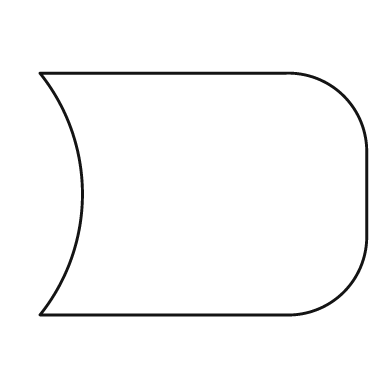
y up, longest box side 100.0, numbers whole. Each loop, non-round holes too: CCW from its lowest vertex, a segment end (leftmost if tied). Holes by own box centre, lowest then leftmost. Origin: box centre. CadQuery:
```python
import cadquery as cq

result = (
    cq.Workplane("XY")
    .moveTo(-50.0, -37.0)
    .lineTo(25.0, -37.0)
    .threePointArc((43.0, -30.0), (50.0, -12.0))
    .lineTo(50.0, 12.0)
    .threePointArc((43.0, 30.0), (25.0, 37.0))
    .lineTo(-50.0, 37.0)
    .threePointArc((-37.0, 0.0), (-50.0, -37.0))
    .close()
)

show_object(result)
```